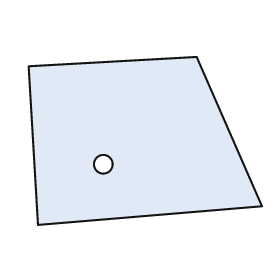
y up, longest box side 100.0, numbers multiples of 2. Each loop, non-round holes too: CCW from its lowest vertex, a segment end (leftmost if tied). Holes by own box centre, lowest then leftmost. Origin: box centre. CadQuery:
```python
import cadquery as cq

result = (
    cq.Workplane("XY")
    .moveTo(-46.0, -36.0)
    .lineTo(50.0, -28.0)
    .lineTo(22.0, 36.0)
    .lineTo(-50.0, 32.0)
    .close()
    .moveTo(-18.0, -10.0)
    .circle(4.0)
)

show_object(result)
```